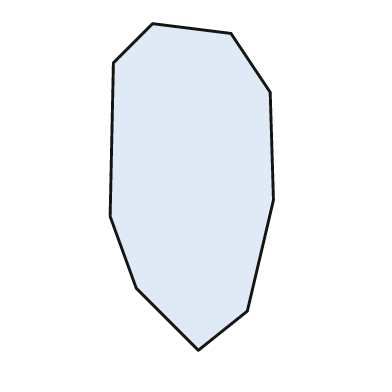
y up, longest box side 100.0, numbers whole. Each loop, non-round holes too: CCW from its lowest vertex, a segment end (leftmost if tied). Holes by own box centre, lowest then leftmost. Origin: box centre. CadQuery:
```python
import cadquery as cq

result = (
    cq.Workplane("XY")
    .moveTo(2.0, -50.0)
    .lineTo(17.0, -38.0)
    .lineTo(25.0, -4.0)
    .lineTo(24.0, 29.0)
    .lineTo(12.0, 47.0)
    .lineTo(-12.0, 50.0)
    .lineTo(-24.0, 38.0)
    .lineTo(-25.0, -9.0)
    .lineTo(-17.0, -31.0)
    .close()
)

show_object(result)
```